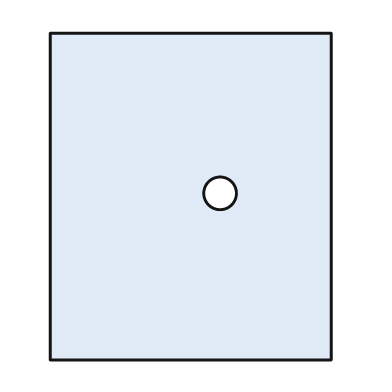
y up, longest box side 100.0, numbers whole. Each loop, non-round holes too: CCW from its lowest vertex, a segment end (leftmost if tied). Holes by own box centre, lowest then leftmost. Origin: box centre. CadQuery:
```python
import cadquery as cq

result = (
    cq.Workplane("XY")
    .moveTo(-43.0, -50.0)
    .lineTo(43.0, -50.0)
    .lineTo(43.0, 50.0)
    .lineTo(-43.0, 50.0)
    .close()
    .moveTo(9.0, 1.0)
    .circle(5.0)
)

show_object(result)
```